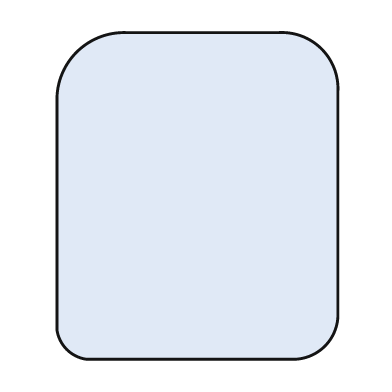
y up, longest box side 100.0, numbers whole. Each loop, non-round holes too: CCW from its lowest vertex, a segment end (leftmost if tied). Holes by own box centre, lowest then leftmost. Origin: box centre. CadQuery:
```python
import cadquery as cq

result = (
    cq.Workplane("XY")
    .moveTo(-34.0, -50.0)
    .lineTo(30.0, -50.0)
    .threePointArc((39.0, -46.0), (43.0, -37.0))
    .lineTo(43.0, 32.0)
    .threePointArc((38.0, 45.0), (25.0, 50.0))
    .lineTo(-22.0, 50.0)
    .threePointArc((-37.0, 44.0), (-43.0, 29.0))
    .lineTo(-43.0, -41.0)
    .threePointArc((-40.0, -47.0), (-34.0, -50.0))
    .close()
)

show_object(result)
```